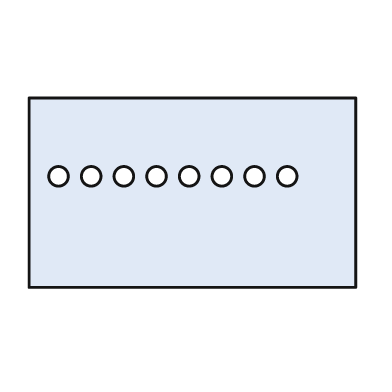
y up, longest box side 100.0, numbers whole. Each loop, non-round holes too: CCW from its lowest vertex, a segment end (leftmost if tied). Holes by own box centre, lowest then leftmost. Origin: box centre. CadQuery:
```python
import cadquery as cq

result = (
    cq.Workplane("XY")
    .moveTo(-50.0, -29.0)
    .lineTo(50.0, -29.0)
    .lineTo(50.0, 29.0)
    .lineTo(-50.0, 29.0)
    .close()
    .moveTo(-41.0, 5.0)
    .circle(3.0)
    .moveTo(-31.0, 5.0)
    .circle(3.0)
    .moveTo(-21.0, 5.0)
    .circle(3.0)
    .moveTo(-11.0, 5.0)
    .circle(3.0)
    .moveTo(-1.0, 5.0)
    .circle(3.0)
    .moveTo(9.0, 5.0)
    .circle(3.0)
    .moveTo(19.0, 5.0)
    .circle(3.0)
    .moveTo(29.0, 5.0)
    .circle(3.0)
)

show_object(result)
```